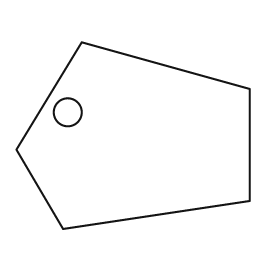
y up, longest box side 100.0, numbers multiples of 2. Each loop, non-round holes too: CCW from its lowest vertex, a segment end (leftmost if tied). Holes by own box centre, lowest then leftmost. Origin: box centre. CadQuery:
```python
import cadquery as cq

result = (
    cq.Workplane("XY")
    .moveTo(-30.0, -40.0)
    .lineTo(50.0, -28.0)
    .lineTo(50.0, 20.0)
    .lineTo(-22.0, 40.0)
    .lineTo(-50.0, -6.0)
    .close()
    .moveTo(-28.0, 10.0)
    .circle(6.0)
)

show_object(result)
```